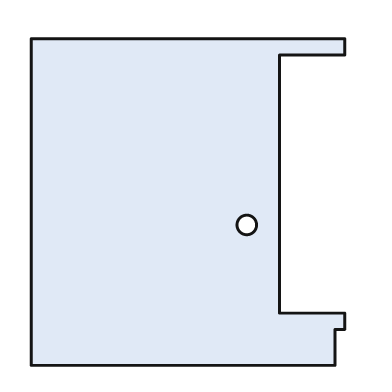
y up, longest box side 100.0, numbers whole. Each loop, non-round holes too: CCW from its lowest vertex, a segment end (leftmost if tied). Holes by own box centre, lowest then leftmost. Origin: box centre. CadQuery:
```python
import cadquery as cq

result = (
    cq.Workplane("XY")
    .moveTo(-48.0, -50.0)
    .lineTo(45.0, -50.0)
    .lineTo(45.0, -39.0)
    .lineTo(48.0, -39.0)
    .lineTo(48.0, -34.0)
    .lineTo(28.0, -34.0)
    .lineTo(28.0, 45.0)
    .lineTo(48.0, 45.0)
    .lineTo(48.0, 50.0)
    .lineTo(-48.0, 50.0)
    .close()
    .moveTo(18.0, -7.0)
    .circle(3.0)
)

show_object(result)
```